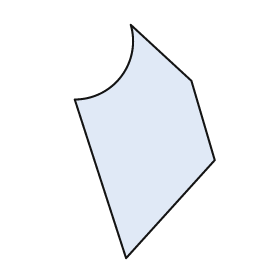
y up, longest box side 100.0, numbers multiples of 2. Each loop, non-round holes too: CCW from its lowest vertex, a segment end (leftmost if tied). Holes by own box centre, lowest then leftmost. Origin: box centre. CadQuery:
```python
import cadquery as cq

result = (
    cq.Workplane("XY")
    .moveTo(-8.0, -50.0)
    .lineTo(30.0, -8.0)
    .lineTo(20.0, 26.0)
    .lineTo(-6.0, 50.0)
    .threePointArc((-10.0, 28.0), (-30.0, 18.0))
    .close()
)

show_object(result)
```